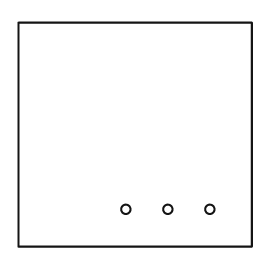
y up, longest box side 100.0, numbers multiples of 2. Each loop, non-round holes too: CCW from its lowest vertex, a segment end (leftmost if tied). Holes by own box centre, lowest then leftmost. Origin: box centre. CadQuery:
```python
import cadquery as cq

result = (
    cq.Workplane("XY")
    .moveTo(-50.0, -48.0)
    .lineTo(50.0, -48.0)
    .lineTo(50.0, 48.0)
    .lineTo(-50.0, 48.0)
    .close()
    .moveTo(-4.0, -32.0)
    .circle(2.0)
    .moveTo(14.0, -32.0)
    .circle(2.0)
    .moveTo(32.0, -32.0)
    .circle(2.0)
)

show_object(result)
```